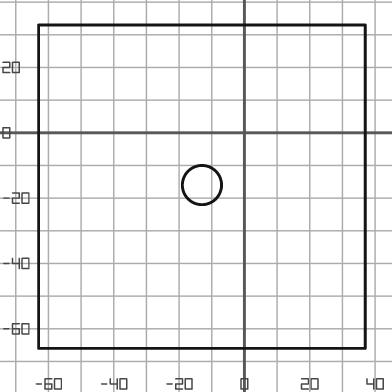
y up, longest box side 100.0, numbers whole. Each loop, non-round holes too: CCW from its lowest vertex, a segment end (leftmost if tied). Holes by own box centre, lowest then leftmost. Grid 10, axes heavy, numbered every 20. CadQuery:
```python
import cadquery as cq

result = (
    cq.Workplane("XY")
    .moveTo(-63.0, -66.0)
    .lineTo(37.0, -66.0)
    .lineTo(37.0, 33.0)
    .lineTo(-63.0, 33.0)
    .close()
    .moveTo(-13.0, -16.0)
    .circle(6.0)
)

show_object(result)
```